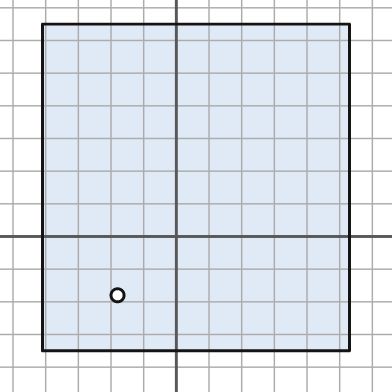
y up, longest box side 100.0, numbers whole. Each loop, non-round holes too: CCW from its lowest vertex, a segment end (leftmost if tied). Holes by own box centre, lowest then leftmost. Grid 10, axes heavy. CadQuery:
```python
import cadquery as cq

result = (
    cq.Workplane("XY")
    .moveTo(-41.0, -35.0)
    .lineTo(53.0, -35.0)
    .lineTo(53.0, 65.0)
    .lineTo(-41.0, 65.0)
    .close()
    .moveTo(-18.0, -18.0)
    .circle(2.0)
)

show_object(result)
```